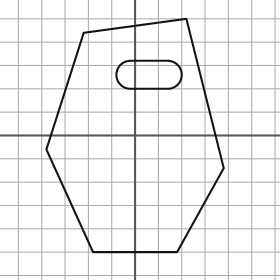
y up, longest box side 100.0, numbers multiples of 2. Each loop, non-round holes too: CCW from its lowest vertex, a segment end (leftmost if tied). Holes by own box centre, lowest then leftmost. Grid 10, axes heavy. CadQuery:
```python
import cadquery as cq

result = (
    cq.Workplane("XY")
    .moveTo(-18.0, -50.0)
    .lineTo(18.0, -50.0)
    .lineTo(38.0, -14.0)
    .lineTo(22.0, 50.0)
    .lineTo(-22.0, 44.0)
    .lineTo(-38.0, -6.0)
    .close()
    .moveTo(-2.0, 20.0)
    .lineTo(14.0, 20.0)
    .threePointArc((20.0, 26.0), (14.0, 32.0))
    .lineTo(-2.0, 32.0)
    .threePointArc((-8.0, 26.0), (-2.0, 20.0))
    .close()
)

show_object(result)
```